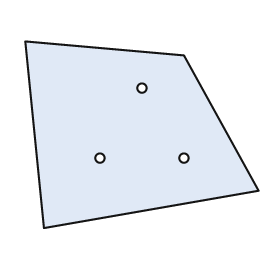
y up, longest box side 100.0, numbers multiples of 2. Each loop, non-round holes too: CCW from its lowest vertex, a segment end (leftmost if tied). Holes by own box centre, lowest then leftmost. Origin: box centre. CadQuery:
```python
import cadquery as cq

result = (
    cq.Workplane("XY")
    .moveTo(-42.0, -40.0)
    .lineTo(50.0, -24.0)
    .lineTo(18.0, 34.0)
    .lineTo(-50.0, 40.0)
    .close()
    .moveTo(-18.0, -10.0)
    .circle(2.0)
    .moveTo(18.0, -10.0)
    .circle(2.0)
    .moveTo(0.0, 20.0)
    .circle(2.0)
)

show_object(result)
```